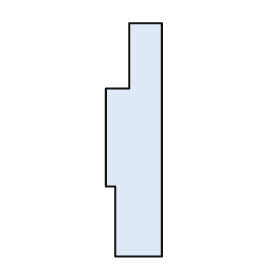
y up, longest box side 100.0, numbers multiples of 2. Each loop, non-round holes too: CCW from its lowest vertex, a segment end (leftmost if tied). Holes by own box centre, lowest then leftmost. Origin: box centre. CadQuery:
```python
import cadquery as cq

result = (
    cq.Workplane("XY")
    .moveTo(-8.0, -50.0)
    .lineTo(12.0, -50.0)
    .lineTo(12.0, 50.0)
    .lineTo(-2.0, 50.0)
    .lineTo(-2.0, 22.0)
    .lineTo(-12.0, 22.0)
    .lineTo(-12.0, -20.0)
    .lineTo(-8.0, -20.0)
    .close()
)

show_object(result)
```